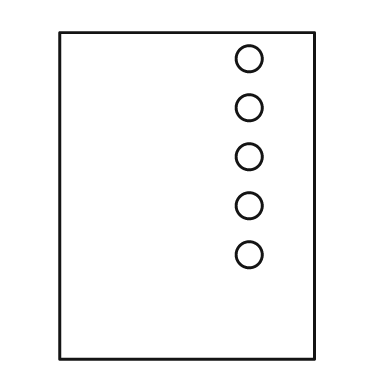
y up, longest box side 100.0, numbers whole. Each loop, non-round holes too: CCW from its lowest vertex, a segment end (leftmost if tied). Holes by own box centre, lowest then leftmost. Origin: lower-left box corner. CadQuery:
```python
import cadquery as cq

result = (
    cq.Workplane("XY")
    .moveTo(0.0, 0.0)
    .lineTo(78.0, 0.0)
    .lineTo(78.0, 100.0)
    .lineTo(0.0, 100.0)
    .close()
    .moveTo(58.0, 32.0)
    .circle(4.0)
    .moveTo(58.0, 47.0)
    .circle(4.0)
    .moveTo(58.0, 62.0)
    .circle(4.0)
    .moveTo(58.0, 77.0)
    .circle(4.0)
    .moveTo(58.0, 92.0)
    .circle(4.0)
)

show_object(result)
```